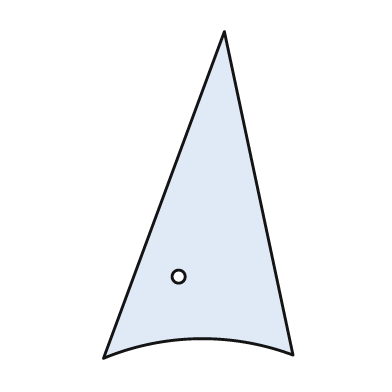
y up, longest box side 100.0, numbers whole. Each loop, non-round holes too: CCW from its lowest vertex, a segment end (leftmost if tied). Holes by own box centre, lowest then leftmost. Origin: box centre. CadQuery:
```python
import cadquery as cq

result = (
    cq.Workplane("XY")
    .moveTo(-29.0, -50.0)
    .threePointArc((0.0, -44.0), (29.0, -49.0))
    .lineTo(8.0, 50.0)
    .close()
    .moveTo(-6.0, -25.0)
    .circle(2.0)
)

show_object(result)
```